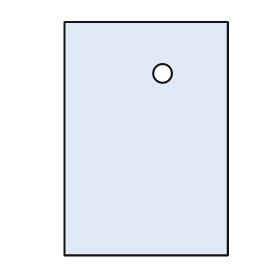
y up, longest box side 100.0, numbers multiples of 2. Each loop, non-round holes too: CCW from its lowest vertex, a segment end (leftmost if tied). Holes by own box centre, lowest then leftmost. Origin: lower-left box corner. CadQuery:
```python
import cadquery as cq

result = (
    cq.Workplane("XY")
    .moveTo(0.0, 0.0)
    .lineTo(70.0, 0.0)
    .lineTo(70.0, 100.0)
    .lineTo(0.0, 100.0)
    .close()
    .moveTo(42.0, 78.0)
    .circle(4.0)
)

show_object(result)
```